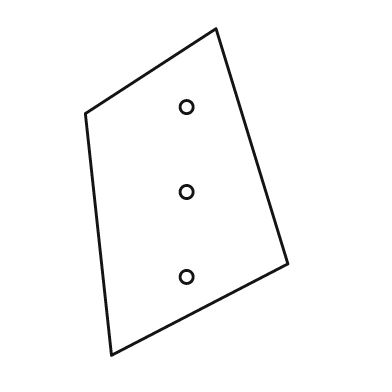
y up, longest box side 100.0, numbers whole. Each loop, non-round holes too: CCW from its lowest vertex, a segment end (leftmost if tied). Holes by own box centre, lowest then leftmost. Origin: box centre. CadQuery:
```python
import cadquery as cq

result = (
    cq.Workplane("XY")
    .moveTo(-23.0, -50.0)
    .lineTo(31.0, -22.0)
    .lineTo(9.0, 50.0)
    .lineTo(-31.0, 24.0)
    .close()
    .moveTo(0.0, -26.0)
    .circle(2.0)
    .moveTo(0.0, 0.0)
    .circle(2.0)
    .moveTo(0.0, 26.0)
    .circle(2.0)
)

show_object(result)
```